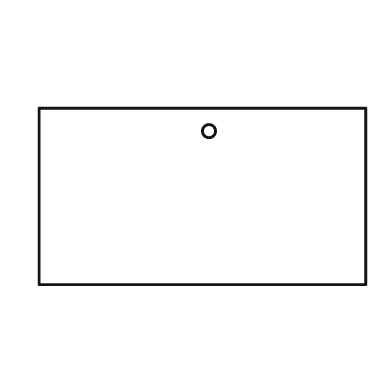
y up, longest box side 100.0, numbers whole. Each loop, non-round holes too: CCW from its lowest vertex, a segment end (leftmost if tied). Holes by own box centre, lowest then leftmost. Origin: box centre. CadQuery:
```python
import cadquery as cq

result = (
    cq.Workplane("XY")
    .moveTo(-50.0, -27.0)
    .lineTo(50.0, -27.0)
    .lineTo(50.0, 27.0)
    .lineTo(-50.0, 27.0)
    .close()
    .moveTo(2.0, 20.0)
    .circle(2.0)
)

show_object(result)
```